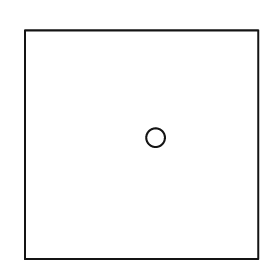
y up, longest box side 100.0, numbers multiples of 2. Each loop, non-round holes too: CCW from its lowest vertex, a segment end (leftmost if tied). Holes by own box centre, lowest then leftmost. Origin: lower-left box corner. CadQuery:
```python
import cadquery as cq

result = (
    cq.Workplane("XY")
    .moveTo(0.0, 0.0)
    .lineTo(100.0, 0.0)
    .lineTo(100.0, 98.0)
    .lineTo(0.0, 98.0)
    .close()
    .moveTo(56.0, 52.0)
    .circle(4.0)
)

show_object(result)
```